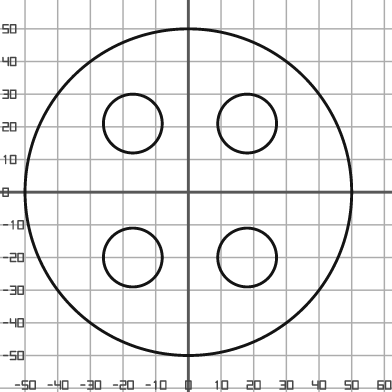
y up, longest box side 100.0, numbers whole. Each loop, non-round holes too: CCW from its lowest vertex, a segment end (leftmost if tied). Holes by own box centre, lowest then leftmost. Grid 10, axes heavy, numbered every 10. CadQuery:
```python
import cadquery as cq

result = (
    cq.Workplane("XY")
    .moveTo(0.0, 0.0)
    .circle(50.0)
    .moveTo(-17.0, -20.0)
    .circle(9.0)
    .moveTo(18.0, -20.0)
    .circle(9.0)
    .moveTo(-17.0, 21.0)
    .circle(9.0)
    .moveTo(18.0, 21.0)
    .circle(9.0)
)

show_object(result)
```